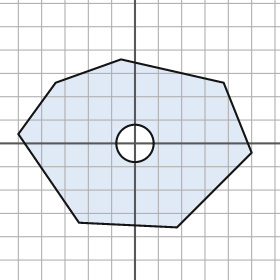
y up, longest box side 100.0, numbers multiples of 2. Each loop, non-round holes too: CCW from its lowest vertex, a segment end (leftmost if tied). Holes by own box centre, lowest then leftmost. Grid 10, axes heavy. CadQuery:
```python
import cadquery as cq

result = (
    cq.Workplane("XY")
    .moveTo(18.0, -36.0)
    .lineTo(50.0, -4.0)
    .lineTo(38.0, 26.0)
    .lineTo(-6.0, 36.0)
    .lineTo(-34.0, 26.0)
    .lineTo(-50.0, 4.0)
    .lineTo(-24.0, -34.0)
    .close()
    .moveTo(0.0, 0.0)
    .circle(8.0)
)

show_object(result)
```